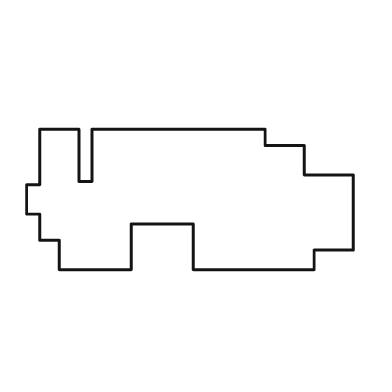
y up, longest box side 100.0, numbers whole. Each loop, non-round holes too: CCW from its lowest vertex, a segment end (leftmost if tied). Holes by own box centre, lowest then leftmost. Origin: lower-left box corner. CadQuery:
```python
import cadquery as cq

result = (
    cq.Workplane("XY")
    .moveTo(10.0, 0.0)
    .lineTo(32.0, 0.0)
    .lineTo(32.0, 14.0)
    .lineTo(51.0, 14.0)
    .lineTo(51.0, 0.0)
    .lineTo(88.0, 0.0)
    .lineTo(88.0, 6.0)
    .lineTo(100.0, 6.0)
    .lineTo(100.0, 29.0)
    .lineTo(85.0, 29.0)
    .lineTo(85.0, 38.0)
    .lineTo(73.0, 38.0)
    .lineTo(73.0, 43.0)
    .lineTo(20.0, 43.0)
    .lineTo(20.0, 27.0)
    .lineTo(16.0, 27.0)
    .lineTo(16.0, 43.0)
    .lineTo(4.0, 43.0)
    .lineTo(4.0, 26.0)
    .lineTo(0.0, 26.0)
    .lineTo(0.0, 17.0)
    .lineTo(4.0, 17.0)
    .lineTo(4.0, 9.0)
    .lineTo(10.0, 9.0)
    .close()
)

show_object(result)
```